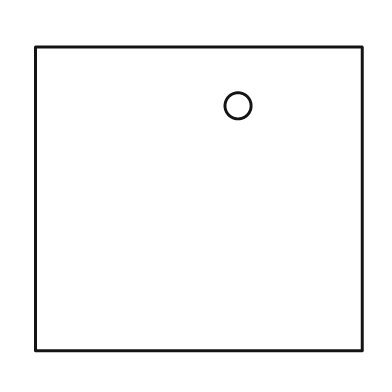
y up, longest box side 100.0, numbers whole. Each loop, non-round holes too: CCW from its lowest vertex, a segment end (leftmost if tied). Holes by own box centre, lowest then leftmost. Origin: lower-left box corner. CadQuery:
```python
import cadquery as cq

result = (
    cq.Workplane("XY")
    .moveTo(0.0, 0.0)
    .lineTo(100.0, 0.0)
    .lineTo(100.0, 93.0)
    .lineTo(0.0, 93.0)
    .close()
    .moveTo(62.0, 75.0)
    .circle(4.0)
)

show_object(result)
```